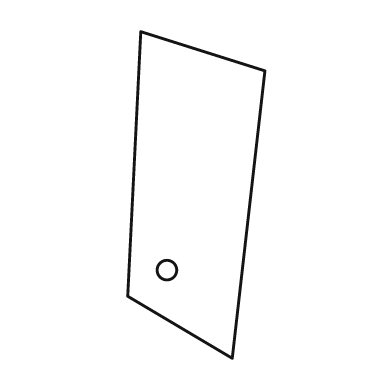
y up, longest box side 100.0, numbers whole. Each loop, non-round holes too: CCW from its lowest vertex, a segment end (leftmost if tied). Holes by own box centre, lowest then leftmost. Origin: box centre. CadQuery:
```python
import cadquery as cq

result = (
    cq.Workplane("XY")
    .moveTo(11.0, -50.0)
    .lineTo(21.0, 38.0)
    .lineTo(-17.0, 50.0)
    .lineTo(-21.0, -31.0)
    .close()
    .moveTo(-9.0, -23.0)
    .circle(3.0)
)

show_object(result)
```